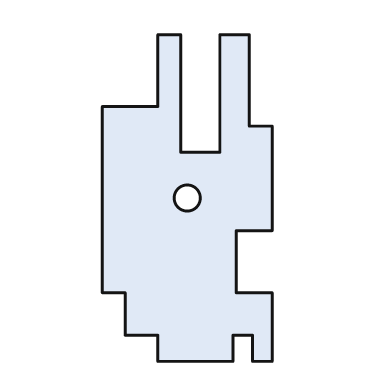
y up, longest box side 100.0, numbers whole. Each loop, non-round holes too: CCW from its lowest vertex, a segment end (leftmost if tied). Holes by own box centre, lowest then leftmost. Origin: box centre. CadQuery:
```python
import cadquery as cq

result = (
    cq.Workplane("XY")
    .moveTo(-9.0, -50.0)
    .lineTo(14.0, -50.0)
    .lineTo(14.0, -42.0)
    .lineTo(20.0, -42.0)
    .lineTo(20.0, -50.0)
    .lineTo(26.0, -50.0)
    .lineTo(26.0, -29.0)
    .lineTo(15.0, -29.0)
    .lineTo(15.0, -10.0)
    .lineTo(26.0, -10.0)
    .lineTo(26.0, 22.0)
    .lineTo(19.0, 22.0)
    .lineTo(19.0, 50.0)
    .lineTo(10.0, 50.0)
    .lineTo(10.0, 14.0)
    .lineTo(-2.0, 14.0)
    .lineTo(-2.0, 50.0)
    .lineTo(-9.0, 50.0)
    .lineTo(-9.0, 28.0)
    .lineTo(-26.0, 28.0)
    .lineTo(-26.0, -29.0)
    .lineTo(-19.0, -29.0)
    .lineTo(-19.0, -42.0)
    .lineTo(-9.0, -42.0)
    .close()
    .moveTo(0.0, 0.0)
    .circle(4.0)
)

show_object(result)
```